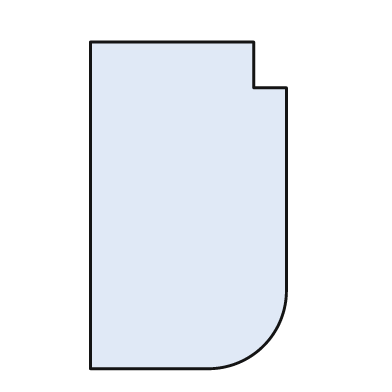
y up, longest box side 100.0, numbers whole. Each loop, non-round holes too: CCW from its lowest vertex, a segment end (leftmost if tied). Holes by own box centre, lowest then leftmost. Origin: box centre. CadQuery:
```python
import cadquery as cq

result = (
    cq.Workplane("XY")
    .moveTo(-30.0, -50.0)
    .lineTo(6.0, -50.0)
    .threePointArc((23.0, -43.0), (30.0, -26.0))
    .lineTo(30.0, 36.0)
    .lineTo(20.0, 36.0)
    .lineTo(20.0, 50.0)
    .lineTo(-30.0, 50.0)
    .close()
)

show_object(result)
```